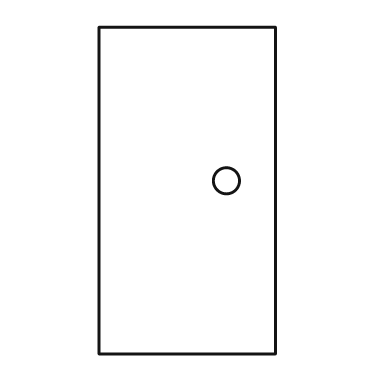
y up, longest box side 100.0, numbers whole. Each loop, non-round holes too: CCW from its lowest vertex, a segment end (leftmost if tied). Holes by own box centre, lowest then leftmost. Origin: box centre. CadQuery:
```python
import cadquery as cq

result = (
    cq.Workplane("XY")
    .moveTo(-27.0, -50.0)
    .lineTo(27.0, -50.0)
    .lineTo(27.0, 50.0)
    .lineTo(-27.0, 50.0)
    .close()
    .moveTo(12.0, 3.0)
    .circle(4.0)
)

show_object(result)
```